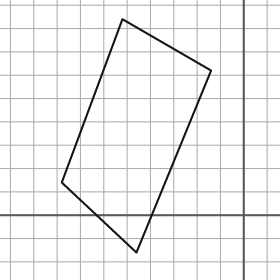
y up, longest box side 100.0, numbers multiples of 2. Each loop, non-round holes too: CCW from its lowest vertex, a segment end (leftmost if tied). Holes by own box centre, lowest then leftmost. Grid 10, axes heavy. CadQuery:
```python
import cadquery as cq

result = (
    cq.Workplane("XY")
    .moveTo(-46.0, -16.0)
    .lineTo(-14.0, 62.0)
    .lineTo(-52.0, 84.0)
    .lineTo(-78.0, 14.0)
    .close()
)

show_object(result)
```